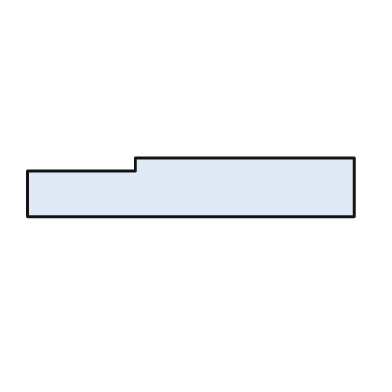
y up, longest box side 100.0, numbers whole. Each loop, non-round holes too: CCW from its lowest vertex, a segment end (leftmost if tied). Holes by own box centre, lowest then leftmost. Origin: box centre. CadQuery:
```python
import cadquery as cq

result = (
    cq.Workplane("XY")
    .moveTo(-50.0, -9.0)
    .lineTo(50.0, -9.0)
    .lineTo(50.0, 9.0)
    .lineTo(-17.0, 9.0)
    .lineTo(-17.0, 5.0)
    .lineTo(-50.0, 5.0)
    .close()
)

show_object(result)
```